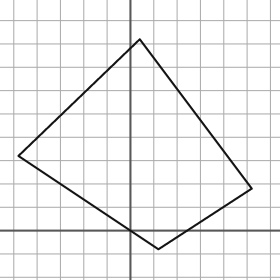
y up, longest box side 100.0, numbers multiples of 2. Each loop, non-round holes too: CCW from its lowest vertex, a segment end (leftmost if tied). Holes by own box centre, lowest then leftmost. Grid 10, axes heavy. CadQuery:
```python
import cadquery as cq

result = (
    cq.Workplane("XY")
    .moveTo(12.0, -8.0)
    .lineTo(52.0, 18.0)
    .lineTo(4.0, 82.0)
    .lineTo(-48.0, 32.0)
    .close()
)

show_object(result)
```